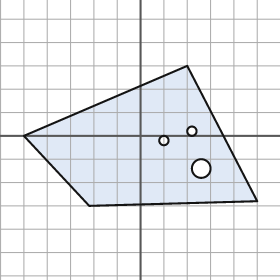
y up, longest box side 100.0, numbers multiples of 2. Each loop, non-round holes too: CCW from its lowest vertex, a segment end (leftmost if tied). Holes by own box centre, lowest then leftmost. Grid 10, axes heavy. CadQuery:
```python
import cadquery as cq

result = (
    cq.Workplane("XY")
    .moveTo(-22.0, -30.0)
    .lineTo(50.0, -28.0)
    .lineTo(20.0, 30.0)
    .lineTo(-50.0, 0.0)
    .close()
    .moveTo(26.0, -14.0)
    .circle(4.0)
    .moveTo(10.0, -2.0)
    .circle(2.0)
    .moveTo(22.0, 2.0)
    .circle(2.0)
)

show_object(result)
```